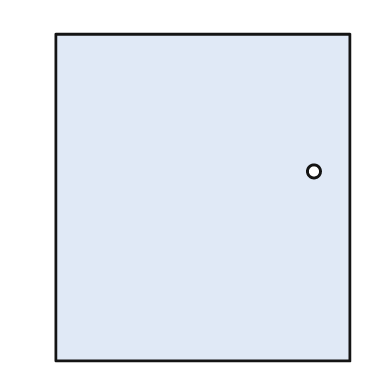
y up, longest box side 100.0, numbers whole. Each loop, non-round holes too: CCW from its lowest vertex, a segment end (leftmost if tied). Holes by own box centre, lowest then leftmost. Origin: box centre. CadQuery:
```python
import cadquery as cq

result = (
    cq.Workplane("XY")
    .moveTo(-45.0, -50.0)
    .lineTo(45.0, -50.0)
    .lineTo(45.0, 50.0)
    .lineTo(-45.0, 50.0)
    .close()
    .moveTo(34.0, 8.0)
    .circle(2.0)
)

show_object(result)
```